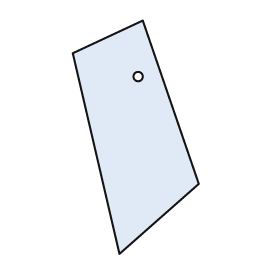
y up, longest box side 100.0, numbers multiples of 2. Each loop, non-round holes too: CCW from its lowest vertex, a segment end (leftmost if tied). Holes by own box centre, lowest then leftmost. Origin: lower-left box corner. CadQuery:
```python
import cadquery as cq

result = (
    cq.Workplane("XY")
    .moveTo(20.0, 0.0)
    .lineTo(54.0, 30.0)
    .lineTo(30.0, 100.0)
    .lineTo(0.0, 86.0)
    .close()
    .moveTo(28.0, 76.0)
    .circle(2.0)
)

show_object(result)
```